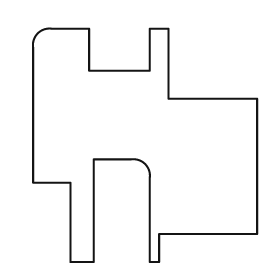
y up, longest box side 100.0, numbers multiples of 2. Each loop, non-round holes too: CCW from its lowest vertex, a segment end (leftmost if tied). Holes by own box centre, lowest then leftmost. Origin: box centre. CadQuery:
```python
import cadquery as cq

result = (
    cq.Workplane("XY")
    .moveTo(-32.0, -50.0)
    .lineTo(-22.0, -50.0)
    .lineTo(-22.0, -6.0)
    .lineTo(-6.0, -6.0)
    .threePointArc((0.0, -8.0), (2.0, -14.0))
    .lineTo(2.0, -50.0)
    .lineTo(6.0, -50.0)
    .lineTo(6.0, -38.0)
    .lineTo(48.0, -38.0)
    .lineTo(48.0, 20.0)
    .lineTo(10.0, 20.0)
    .lineTo(10.0, 50.0)
    .lineTo(2.0, 50.0)
    .lineTo(2.0, 32.0)
    .lineTo(-24.0, 32.0)
    .lineTo(-24.0, 50.0)
    .lineTo(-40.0, 50.0)
    .threePointArc((-46.0, 48.0), (-48.0, 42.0))
    .lineTo(-48.0, -16.0)
    .lineTo(-32.0, -16.0)
    .close()
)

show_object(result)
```